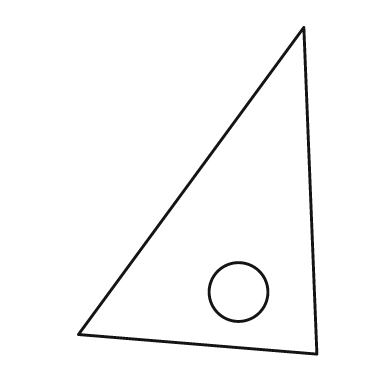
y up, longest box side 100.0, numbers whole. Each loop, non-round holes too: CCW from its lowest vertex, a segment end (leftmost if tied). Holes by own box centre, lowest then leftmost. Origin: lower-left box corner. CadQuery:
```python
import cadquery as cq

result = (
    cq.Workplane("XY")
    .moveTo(73.0, 0.0)
    .lineTo(69.0, 100.0)
    .lineTo(0.0, 6.0)
    .close()
    .moveTo(49.0, 19.0)
    .circle(9.0)
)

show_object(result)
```